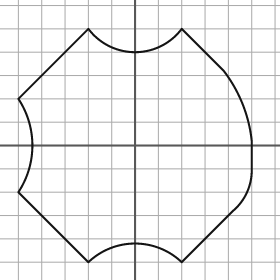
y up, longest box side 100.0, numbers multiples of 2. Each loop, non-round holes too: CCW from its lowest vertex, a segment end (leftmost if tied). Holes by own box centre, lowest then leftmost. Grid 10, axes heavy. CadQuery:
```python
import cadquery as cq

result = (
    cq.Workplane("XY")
    .moveTo(-20.0, -50.0)
    .threePointArc((0.0, -42.0), (20.0, -50.0))
    .lineTo(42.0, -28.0)
    .threePointArc((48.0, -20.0), (50.0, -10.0))
    .lineTo(50.0, 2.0)
    .threePointArc((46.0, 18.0), (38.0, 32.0))
    .lineTo(20.0, 50.0)
    .threePointArc((0.0, 40.0), (-20.0, 50.0))
    .lineTo(-50.0, 20.0)
    .threePointArc((-44.0, 0.0), (-50.0, -20.0))
    .close()
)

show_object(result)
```